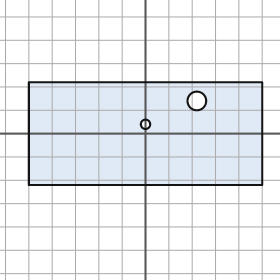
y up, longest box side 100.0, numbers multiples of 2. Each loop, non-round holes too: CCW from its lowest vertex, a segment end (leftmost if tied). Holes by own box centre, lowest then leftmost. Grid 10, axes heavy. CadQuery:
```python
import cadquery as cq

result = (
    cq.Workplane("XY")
    .moveTo(-50.0, -22.0)
    .lineTo(50.0, -22.0)
    .lineTo(50.0, 22.0)
    .lineTo(-50.0, 22.0)
    .close()
    .moveTo(0.0, 4.0)
    .circle(2.0)
    .moveTo(22.0, 14.0)
    .circle(4.0)
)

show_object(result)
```